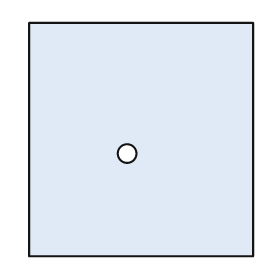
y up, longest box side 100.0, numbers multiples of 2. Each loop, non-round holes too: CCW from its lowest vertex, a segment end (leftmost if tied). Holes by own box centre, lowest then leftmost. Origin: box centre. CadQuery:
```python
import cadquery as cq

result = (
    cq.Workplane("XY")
    .moveTo(-48.0, -50.0)
    .lineTo(48.0, -50.0)
    .lineTo(48.0, 50.0)
    .lineTo(-48.0, 50.0)
    .close()
    .moveTo(-6.0, -6.0)
    .circle(4.0)
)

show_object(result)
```